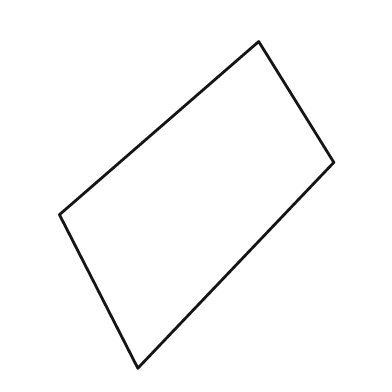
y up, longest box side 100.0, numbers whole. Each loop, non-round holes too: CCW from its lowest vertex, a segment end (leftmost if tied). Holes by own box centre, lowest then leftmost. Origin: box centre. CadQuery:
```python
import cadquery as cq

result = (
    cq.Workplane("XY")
    .moveTo(-18.0, -50.0)
    .lineTo(42.0, 13.0)
    .lineTo(19.0, 50.0)
    .lineTo(-42.0, -3.0)
    .close()
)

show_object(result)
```